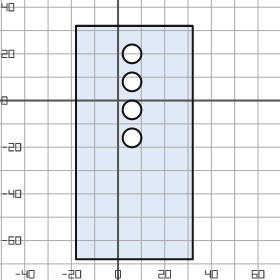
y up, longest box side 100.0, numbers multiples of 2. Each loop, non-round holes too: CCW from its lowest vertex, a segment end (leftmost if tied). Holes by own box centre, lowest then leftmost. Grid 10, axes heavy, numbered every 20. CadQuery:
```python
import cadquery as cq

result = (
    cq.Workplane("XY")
    .moveTo(-18.0, -68.0)
    .lineTo(32.0, -68.0)
    .lineTo(32.0, 32.0)
    .lineTo(-18.0, 32.0)
    .close()
    .moveTo(6.0, -16.0)
    .circle(4.0)
    .moveTo(6.0, -4.0)
    .circle(4.0)
    .moveTo(6.0, 8.0)
    .circle(4.0)
    .moveTo(6.0, 20.0)
    .circle(4.0)
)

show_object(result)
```